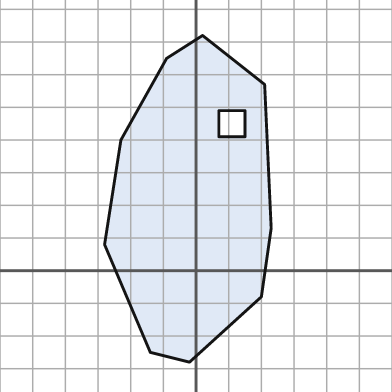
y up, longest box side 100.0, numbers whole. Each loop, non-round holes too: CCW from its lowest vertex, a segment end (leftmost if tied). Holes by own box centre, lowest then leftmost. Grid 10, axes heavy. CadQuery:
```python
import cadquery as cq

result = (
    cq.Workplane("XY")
    .moveTo(-2.0, -28.0)
    .lineTo(20.0, -8.0)
    .lineTo(23.0, 13.0)
    .lineTo(21.0, 57.0)
    .lineTo(2.0, 72.0)
    .lineTo(-9.0, 65.0)
    .lineTo(-23.0, 40.0)
    .lineTo(-28.0, 8.0)
    .lineTo(-14.0, -25.0)
    .close()
    .moveTo(7.0, 41.0)
    .lineTo(15.0, 41.0)
    .lineTo(15.0, 49.0)
    .lineTo(7.0, 49.0)
    .close()
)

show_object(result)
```